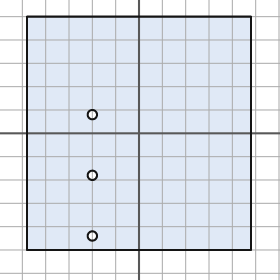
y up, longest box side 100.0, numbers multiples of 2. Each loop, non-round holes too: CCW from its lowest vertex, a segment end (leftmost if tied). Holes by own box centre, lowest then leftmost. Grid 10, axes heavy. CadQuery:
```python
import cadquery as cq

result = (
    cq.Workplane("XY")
    .moveTo(-48.0, -50.0)
    .lineTo(48.0, -50.0)
    .lineTo(48.0, 50.0)
    .lineTo(-48.0, 50.0)
    .close()
    .moveTo(-20.0, -44.0)
    .circle(2.0)
    .moveTo(-20.0, -18.0)
    .circle(2.0)
    .moveTo(-20.0, 8.0)
    .circle(2.0)
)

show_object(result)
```